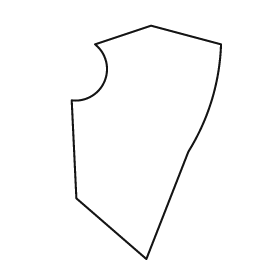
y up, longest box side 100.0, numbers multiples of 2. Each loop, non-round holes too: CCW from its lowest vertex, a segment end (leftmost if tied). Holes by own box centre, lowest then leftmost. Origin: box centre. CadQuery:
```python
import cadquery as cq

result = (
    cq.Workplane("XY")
    .moveTo(0.0, -50.0)
    .lineTo(18.0, -4.0)
    .threePointArc((28.0, 18.0), (32.0, 42.0))
    .lineTo(2.0, 50.0)
    .lineTo(-22.0, 42.0)
    .threePointArc((-18.0, 26.0), (-32.0, 18.0))
    .lineTo(-30.0, -24.0)
    .close()
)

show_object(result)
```